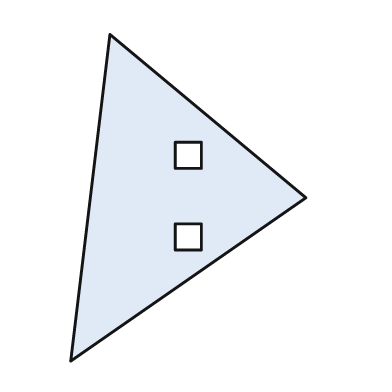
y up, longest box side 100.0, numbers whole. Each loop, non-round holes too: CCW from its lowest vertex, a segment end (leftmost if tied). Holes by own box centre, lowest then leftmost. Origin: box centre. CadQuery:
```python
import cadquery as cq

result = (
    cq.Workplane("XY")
    .moveTo(-36.0, -50.0)
    .lineTo(36.0, 0.0)
    .lineTo(-24.0, 50.0)
    .close()
    .moveTo(-4.0, -16.0)
    .lineTo(4.0, -16.0)
    .lineTo(4.0, -8.0)
    .lineTo(-4.0, -8.0)
    .close()
    .moveTo(-4.0, 9.0)
    .lineTo(4.0, 9.0)
    .lineTo(4.0, 17.0)
    .lineTo(-4.0, 17.0)
    .close()
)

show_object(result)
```